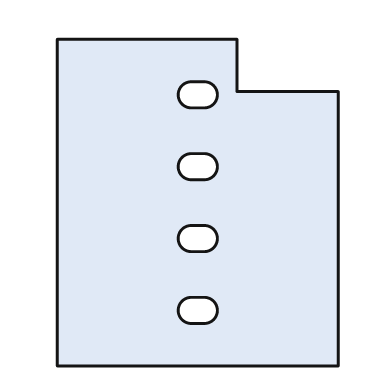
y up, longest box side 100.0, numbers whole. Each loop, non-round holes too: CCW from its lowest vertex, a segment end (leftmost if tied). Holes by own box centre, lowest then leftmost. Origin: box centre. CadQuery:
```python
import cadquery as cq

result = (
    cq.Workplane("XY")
    .moveTo(-43.0, -50.0)
    .lineTo(43.0, -50.0)
    .lineTo(43.0, 34.0)
    .lineTo(12.0, 34.0)
    .lineTo(12.0, 50.0)
    .lineTo(-43.0, 50.0)
    .close()
    .moveTo(-2.0, -37.0)
    .lineTo(2.0, -37.0)
    .threePointArc((6.0, -33.0), (2.0, -29.0))
    .lineTo(-2.0, -29.0)
    .threePointArc((-6.0, -33.0), (-2.0, -37.0))
    .close()
    .moveTo(-2.0, -15.0)
    .lineTo(2.0, -15.0)
    .threePointArc((6.0, -11.0), (2.0, -7.0))
    .lineTo(-2.0, -7.0)
    .threePointArc((-6.0, -11.0), (-2.0, -15.0))
    .close()
    .moveTo(-2.0, 7.0)
    .lineTo(2.0, 7.0)
    .threePointArc((6.0, 11.0), (2.0, 15.0))
    .lineTo(-2.0, 15.0)
    .threePointArc((-6.0, 11.0), (-2.0, 7.0))
    .close()
    .moveTo(-2.0, 29.0)
    .lineTo(2.0, 29.0)
    .threePointArc((6.0, 33.0), (2.0, 37.0))
    .lineTo(-2.0, 37.0)
    .threePointArc((-6.0, 33.0), (-2.0, 29.0))
    .close()
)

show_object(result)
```